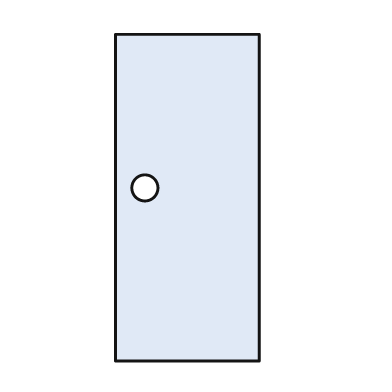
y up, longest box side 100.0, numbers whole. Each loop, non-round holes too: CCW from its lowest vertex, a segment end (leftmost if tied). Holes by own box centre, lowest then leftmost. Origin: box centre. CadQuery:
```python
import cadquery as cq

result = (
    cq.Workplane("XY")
    .moveTo(-22.0, -50.0)
    .lineTo(22.0, -50.0)
    .lineTo(22.0, 50.0)
    .lineTo(-22.0, 50.0)
    .close()
    .moveTo(-13.0, 3.0)
    .circle(4.0)
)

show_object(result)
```